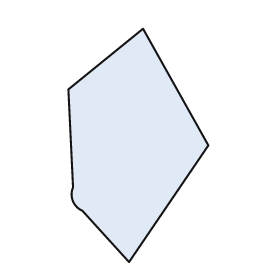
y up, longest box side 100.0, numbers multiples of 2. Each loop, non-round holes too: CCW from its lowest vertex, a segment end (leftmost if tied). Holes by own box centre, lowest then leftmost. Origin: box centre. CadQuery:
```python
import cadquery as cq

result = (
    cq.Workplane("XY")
    .moveTo(-4.0, -50.0)
    .lineTo(30.0, 0.0)
    .lineTo(2.0, 50.0)
    .lineTo(-30.0, 24.0)
    .lineTo(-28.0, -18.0)
    .threePointArc((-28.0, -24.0), (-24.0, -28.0))
    .close()
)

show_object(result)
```